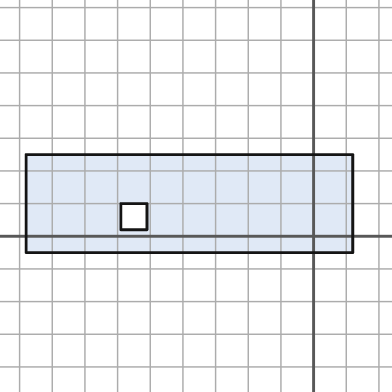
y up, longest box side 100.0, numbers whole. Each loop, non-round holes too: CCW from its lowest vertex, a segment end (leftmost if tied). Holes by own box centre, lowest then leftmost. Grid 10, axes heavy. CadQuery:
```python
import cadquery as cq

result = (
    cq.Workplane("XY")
    .moveTo(-88.0, -5.0)
    .lineTo(12.0, -5.0)
    .lineTo(12.0, 25.0)
    .lineTo(-88.0, 25.0)
    .close()
    .moveTo(-59.0, 2.0)
    .lineTo(-51.0, 2.0)
    .lineTo(-51.0, 10.0)
    .lineTo(-59.0, 10.0)
    .close()
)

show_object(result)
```